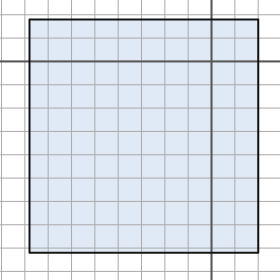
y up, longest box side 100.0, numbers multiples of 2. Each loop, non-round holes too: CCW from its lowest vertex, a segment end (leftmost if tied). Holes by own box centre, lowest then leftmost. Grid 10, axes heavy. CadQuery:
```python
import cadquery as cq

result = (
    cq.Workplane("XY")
    .moveTo(-78.0, -82.0)
    .lineTo(20.0, -82.0)
    .lineTo(20.0, 18.0)
    .lineTo(-78.0, 18.0)
    .close()
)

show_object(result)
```